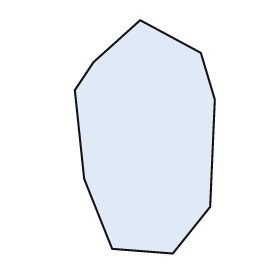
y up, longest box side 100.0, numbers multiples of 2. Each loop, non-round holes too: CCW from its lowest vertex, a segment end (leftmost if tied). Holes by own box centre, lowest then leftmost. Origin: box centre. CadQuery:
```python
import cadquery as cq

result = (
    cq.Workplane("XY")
    .moveTo(12.0, -50.0)
    .lineTo(28.0, -30.0)
    .lineTo(30.0, 16.0)
    .lineTo(24.0, 36.0)
    .lineTo(-2.0, 50.0)
    .lineTo(-22.0, 32.0)
    .lineTo(-30.0, 20.0)
    .lineTo(-26.0, -18.0)
    .lineTo(-14.0, -48.0)
    .close()
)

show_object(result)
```